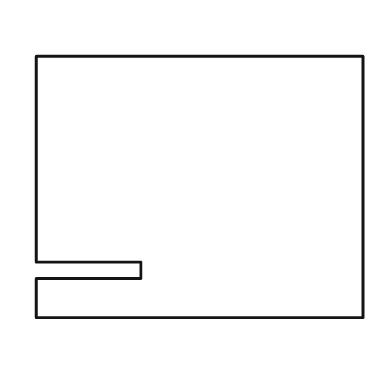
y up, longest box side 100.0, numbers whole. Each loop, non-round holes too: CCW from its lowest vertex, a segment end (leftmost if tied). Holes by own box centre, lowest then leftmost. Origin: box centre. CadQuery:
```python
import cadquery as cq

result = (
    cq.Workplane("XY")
    .moveTo(-50.0, -40.0)
    .lineTo(50.0, -40.0)
    .lineTo(50.0, 40.0)
    .lineTo(-50.0, 40.0)
    .lineTo(-50.0, -23.0)
    .lineTo(-18.0, -23.0)
    .lineTo(-18.0, -28.0)
    .lineTo(-50.0, -28.0)
    .close()
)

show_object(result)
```